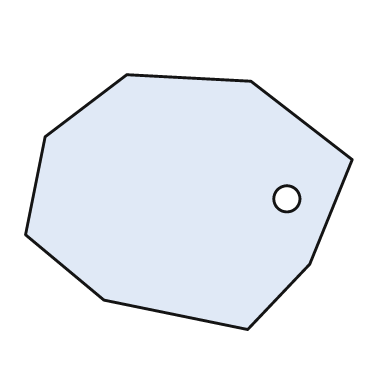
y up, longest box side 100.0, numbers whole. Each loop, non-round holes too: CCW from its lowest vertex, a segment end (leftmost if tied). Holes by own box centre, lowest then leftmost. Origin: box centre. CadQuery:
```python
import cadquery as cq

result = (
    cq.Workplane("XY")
    .moveTo(18.0, -39.0)
    .lineTo(37.0, -19.0)
    .lineTo(50.0, 13.0)
    .lineTo(19.0, 37.0)
    .lineTo(-19.0, 39.0)
    .lineTo(-44.0, 20.0)
    .lineTo(-50.0, -10.0)
    .lineTo(-26.0, -30.0)
    .close()
    .moveTo(30.0, 1.0)
    .circle(4.0)
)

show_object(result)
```